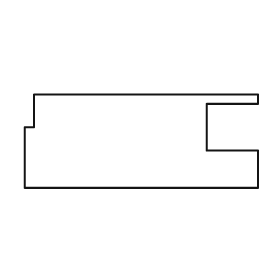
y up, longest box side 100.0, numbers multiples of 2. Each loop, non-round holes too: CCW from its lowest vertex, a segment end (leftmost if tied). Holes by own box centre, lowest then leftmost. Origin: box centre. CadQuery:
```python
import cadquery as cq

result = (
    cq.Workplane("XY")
    .moveTo(-50.0, -20.0)
    .lineTo(50.0, -20.0)
    .lineTo(50.0, -4.0)
    .lineTo(28.0, -4.0)
    .lineTo(28.0, 16.0)
    .lineTo(50.0, 16.0)
    .lineTo(50.0, 20.0)
    .lineTo(-46.0, 20.0)
    .lineTo(-46.0, 6.0)
    .lineTo(-50.0, 6.0)
    .close()
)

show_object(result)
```